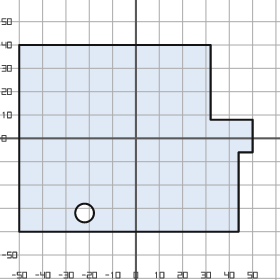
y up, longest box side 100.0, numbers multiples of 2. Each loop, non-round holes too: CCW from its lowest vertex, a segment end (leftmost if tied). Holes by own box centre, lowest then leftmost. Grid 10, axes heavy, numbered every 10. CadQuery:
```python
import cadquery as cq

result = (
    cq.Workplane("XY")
    .moveTo(-50.0, -40.0)
    .lineTo(44.0, -40.0)
    .lineTo(44.0, -6.0)
    .lineTo(50.0, -6.0)
    .lineTo(50.0, 8.0)
    .lineTo(32.0, 8.0)
    .lineTo(32.0, 40.0)
    .lineTo(-50.0, 40.0)
    .close()
    .moveTo(-22.0, -32.0)
    .circle(4.0)
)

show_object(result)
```